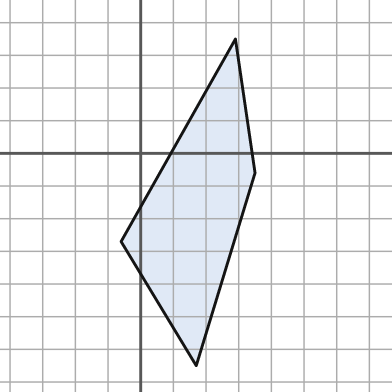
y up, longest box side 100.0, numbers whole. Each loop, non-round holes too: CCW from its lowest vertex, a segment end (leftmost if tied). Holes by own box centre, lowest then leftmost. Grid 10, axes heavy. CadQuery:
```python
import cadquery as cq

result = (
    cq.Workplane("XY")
    .moveTo(17.0, -65.0)
    .lineTo(35.0, -6.0)
    .lineTo(29.0, 35.0)
    .lineTo(-6.0, -27.0)
    .close()
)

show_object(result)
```